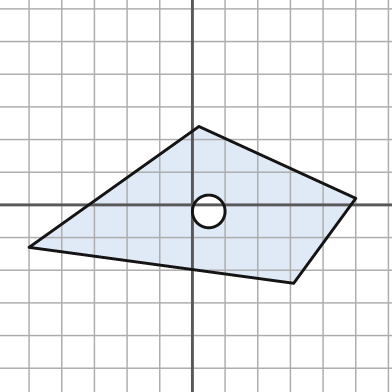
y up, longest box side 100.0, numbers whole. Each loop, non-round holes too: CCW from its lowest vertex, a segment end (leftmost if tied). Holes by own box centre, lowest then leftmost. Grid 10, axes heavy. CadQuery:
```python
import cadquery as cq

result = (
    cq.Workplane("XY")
    .moveTo(31.0, -24.0)
    .lineTo(50.0, 2.0)
    .lineTo(2.0, 24.0)
    .lineTo(-50.0, -13.0)
    .close()
    .moveTo(5.0, -2.0)
    .circle(5.0)
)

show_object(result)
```